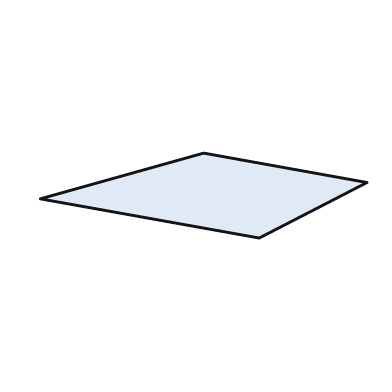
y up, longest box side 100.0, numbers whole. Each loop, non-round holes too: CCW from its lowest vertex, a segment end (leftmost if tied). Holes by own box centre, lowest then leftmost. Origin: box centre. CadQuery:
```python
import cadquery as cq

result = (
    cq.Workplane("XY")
    .moveTo(17.0, -13.0)
    .lineTo(50.0, 4.0)
    .lineTo(0.0, 13.0)
    .lineTo(-50.0, -1.0)
    .close()
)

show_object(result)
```